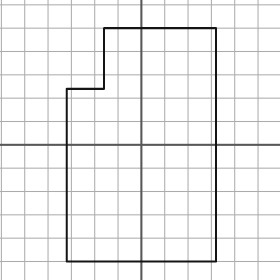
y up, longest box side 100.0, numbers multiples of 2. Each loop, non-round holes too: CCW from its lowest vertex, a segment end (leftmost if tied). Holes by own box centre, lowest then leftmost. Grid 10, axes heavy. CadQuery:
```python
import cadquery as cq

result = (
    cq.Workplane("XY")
    .moveTo(-32.0, -50.0)
    .lineTo(32.0, -50.0)
    .lineTo(32.0, 50.0)
    .lineTo(-16.0, 50.0)
    .lineTo(-16.0, 24.0)
    .lineTo(-32.0, 24.0)
    .close()
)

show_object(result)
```